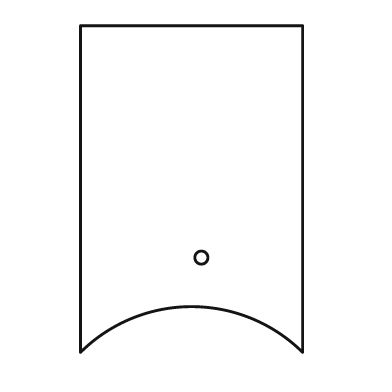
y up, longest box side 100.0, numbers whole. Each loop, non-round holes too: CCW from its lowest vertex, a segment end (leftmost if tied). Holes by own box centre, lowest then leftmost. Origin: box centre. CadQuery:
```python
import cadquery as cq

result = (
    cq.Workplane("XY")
    .moveTo(-34.0, -50.0)
    .threePointArc((0.0, -36.0), (34.0, -50.0))
    .lineTo(34.0, 50.0)
    .lineTo(-34.0, 50.0)
    .close()
    .moveTo(3.0, -21.0)
    .circle(2.0)
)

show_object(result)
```